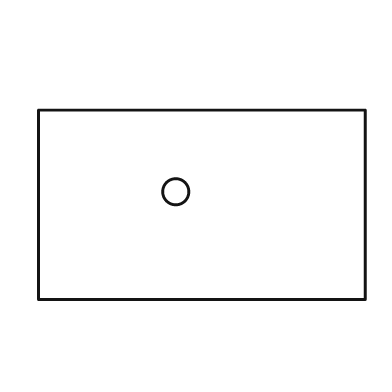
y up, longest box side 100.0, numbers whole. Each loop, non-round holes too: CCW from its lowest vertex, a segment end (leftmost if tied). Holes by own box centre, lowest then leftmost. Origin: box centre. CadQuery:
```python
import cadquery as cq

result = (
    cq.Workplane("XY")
    .moveTo(-50.0, -29.0)
    .lineTo(50.0, -29.0)
    .lineTo(50.0, 29.0)
    .lineTo(-50.0, 29.0)
    .close()
    .moveTo(-8.0, 4.0)
    .circle(4.0)
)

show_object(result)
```